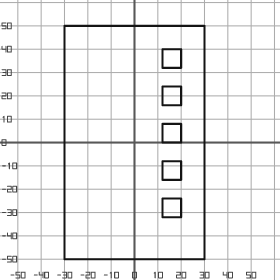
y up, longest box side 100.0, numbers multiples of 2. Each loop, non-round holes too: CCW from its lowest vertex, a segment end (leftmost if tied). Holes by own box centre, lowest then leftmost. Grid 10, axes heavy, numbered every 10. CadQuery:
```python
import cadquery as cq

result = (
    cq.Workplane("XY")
    .moveTo(-30.0, -50.0)
    .lineTo(30.0, -50.0)
    .lineTo(30.0, 50.0)
    .lineTo(-30.0, 50.0)
    .close()
    .moveTo(12.0, -32.0)
    .lineTo(20.0, -32.0)
    .lineTo(20.0, -24.0)
    .lineTo(12.0, -24.0)
    .close()
    .moveTo(12.0, -16.0)
    .lineTo(20.0, -16.0)
    .lineTo(20.0, -8.0)
    .lineTo(12.0, -8.0)
    .close()
    .moveTo(12.0, 0.0)
    .lineTo(20.0, 0.0)
    .lineTo(20.0, 8.0)
    .lineTo(12.0, 8.0)
    .close()
    .moveTo(12.0, 16.0)
    .lineTo(20.0, 16.0)
    .lineTo(20.0, 24.0)
    .lineTo(12.0, 24.0)
    .close()
    .moveTo(12.0, 32.0)
    .lineTo(20.0, 32.0)
    .lineTo(20.0, 40.0)
    .lineTo(12.0, 40.0)
    .close()
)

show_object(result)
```